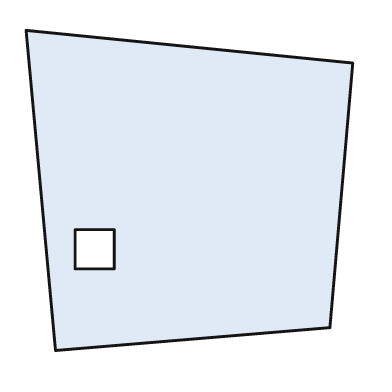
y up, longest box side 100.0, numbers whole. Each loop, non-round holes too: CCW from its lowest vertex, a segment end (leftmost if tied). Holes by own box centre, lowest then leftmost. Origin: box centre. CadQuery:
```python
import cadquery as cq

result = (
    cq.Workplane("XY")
    .moveTo(-41.0, -49.0)
    .lineTo(43.0, -42.0)
    .lineTo(50.0, 39.0)
    .lineTo(-50.0, 49.0)
    .close()
    .moveTo(-35.0, -24.0)
    .lineTo(-23.0, -24.0)
    .lineTo(-23.0, -12.0)
    .lineTo(-35.0, -12.0)
    .close()
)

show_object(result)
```